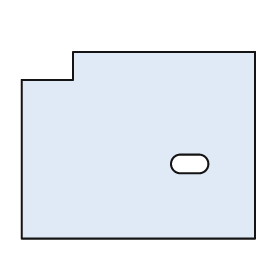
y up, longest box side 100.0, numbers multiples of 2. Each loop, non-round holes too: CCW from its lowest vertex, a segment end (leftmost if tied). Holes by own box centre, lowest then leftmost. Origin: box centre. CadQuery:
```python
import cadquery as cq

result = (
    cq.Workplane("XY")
    .moveTo(-50.0, -40.0)
    .lineTo(50.0, -40.0)
    .lineTo(50.0, 40.0)
    .lineTo(-28.0, 40.0)
    .lineTo(-28.0, 28.0)
    .lineTo(-50.0, 28.0)
    .close()
    .moveTo(18.0, -12.0)
    .lineTo(26.0, -12.0)
    .threePointArc((30.0, -8.0), (26.0, -4.0))
    .lineTo(18.0, -4.0)
    .threePointArc((14.0, -8.0), (18.0, -12.0))
    .close()
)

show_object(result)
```